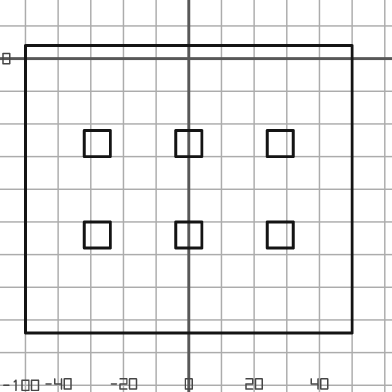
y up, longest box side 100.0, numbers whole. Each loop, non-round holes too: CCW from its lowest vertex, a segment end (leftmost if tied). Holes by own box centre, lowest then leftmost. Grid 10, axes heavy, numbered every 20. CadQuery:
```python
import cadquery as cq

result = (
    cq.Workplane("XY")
    .moveTo(-50.0, -84.0)
    .lineTo(50.0, -84.0)
    .lineTo(50.0, 4.0)
    .lineTo(-50.0, 4.0)
    .close()
    .moveTo(-32.0, -58.0)
    .lineTo(-24.0, -58.0)
    .lineTo(-24.0, -50.0)
    .lineTo(-32.0, -50.0)
    .close()
    .moveTo(-4.0, -58.0)
    .lineTo(4.0, -58.0)
    .lineTo(4.0, -50.0)
    .lineTo(-4.0, -50.0)
    .close()
    .moveTo(24.0, -58.0)
    .lineTo(32.0, -58.0)
    .lineTo(32.0, -50.0)
    .lineTo(24.0, -50.0)
    .close()
    .moveTo(-32.0, -30.0)
    .lineTo(-24.0, -30.0)
    .lineTo(-24.0, -22.0)
    .lineTo(-32.0, -22.0)
    .close()
    .moveTo(-4.0, -30.0)
    .lineTo(4.0, -30.0)
    .lineTo(4.0, -22.0)
    .lineTo(-4.0, -22.0)
    .close()
    .moveTo(24.0, -30.0)
    .lineTo(32.0, -30.0)
    .lineTo(32.0, -22.0)
    .lineTo(24.0, -22.0)
    .close()
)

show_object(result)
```